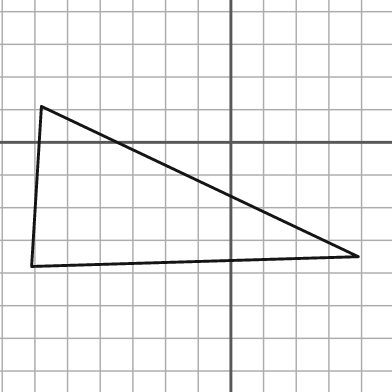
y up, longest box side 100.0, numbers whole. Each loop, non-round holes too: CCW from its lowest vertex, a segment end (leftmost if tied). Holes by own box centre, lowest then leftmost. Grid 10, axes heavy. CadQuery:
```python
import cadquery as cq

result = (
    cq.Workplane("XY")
    .moveTo(-61.0, -38.0)
    .lineTo(39.0, -35.0)
    .lineTo(-58.0, 11.0)
    .close()
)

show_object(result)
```